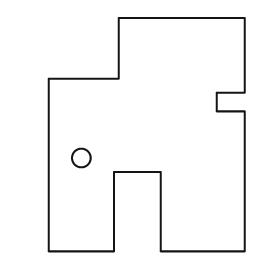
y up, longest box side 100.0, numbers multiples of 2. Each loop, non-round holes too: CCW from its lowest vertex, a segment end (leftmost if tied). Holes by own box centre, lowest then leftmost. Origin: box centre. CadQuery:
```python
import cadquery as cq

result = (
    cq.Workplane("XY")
    .moveTo(-42.0, -50.0)
    .lineTo(-14.0, -50.0)
    .lineTo(-14.0, -16.0)
    .lineTo(6.0, -16.0)
    .lineTo(6.0, -50.0)
    .lineTo(42.0, -50.0)
    .lineTo(42.0, 10.0)
    .lineTo(30.0, 10.0)
    .lineTo(30.0, 18.0)
    .lineTo(42.0, 18.0)
    .lineTo(42.0, 50.0)
    .lineTo(-12.0, 50.0)
    .lineTo(-12.0, 24.0)
    .lineTo(-42.0, 24.0)
    .close()
    .moveTo(-28.0, -10.0)
    .circle(4.0)
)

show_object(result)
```